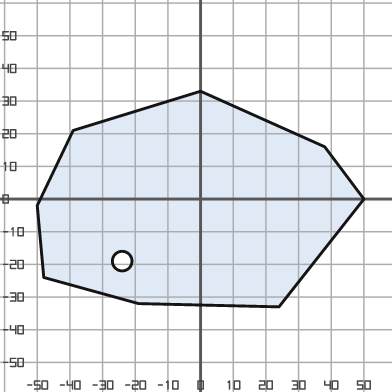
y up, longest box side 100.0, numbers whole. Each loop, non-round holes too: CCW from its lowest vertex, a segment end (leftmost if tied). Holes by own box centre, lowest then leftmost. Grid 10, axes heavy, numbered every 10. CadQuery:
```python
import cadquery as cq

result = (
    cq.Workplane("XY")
    .moveTo(24.0, -33.0)
    .lineTo(50.0, 0.0)
    .lineTo(38.0, 16.0)
    .lineTo(0.0, 33.0)
    .lineTo(-39.0, 21.0)
    .lineTo(-50.0, -2.0)
    .lineTo(-48.0, -24.0)
    .lineTo(-19.0, -32.0)
    .close()
    .moveTo(-24.0, -19.0)
    .circle(3.0)
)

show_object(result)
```